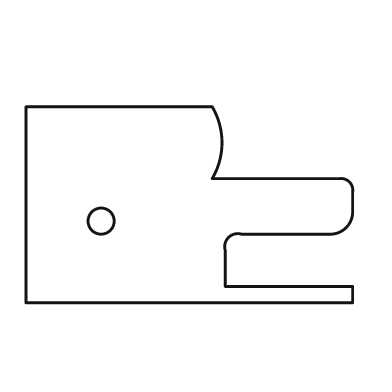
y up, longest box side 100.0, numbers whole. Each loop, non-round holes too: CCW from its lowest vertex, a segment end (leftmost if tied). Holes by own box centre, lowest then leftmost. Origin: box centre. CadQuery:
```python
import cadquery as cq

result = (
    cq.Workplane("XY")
    .moveTo(-50.0, -30.0)
    .lineTo(50.0, -30.0)
    .lineTo(50.0, -25.0)
    .lineTo(11.0, -25.0)
    .lineTo(11.0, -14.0)
    .threePointArc((12.0, -10.0), (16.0, -9.0))
    .lineTo(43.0, -9.0)
    .threePointArc((48.0, -7.0), (50.0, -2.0))
    .lineTo(50.0, 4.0)
    .threePointArc((49.0, 7.0), (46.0, 8.0))
    .lineTo(7.0, 8.0)
    .threePointArc((10.0, 19.0), (7.0, 30.0))
    .lineTo(-50.0, 30.0)
    .close()
    .moveTo(-27.0, -5.0)
    .circle(4.0)
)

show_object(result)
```